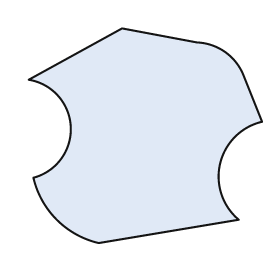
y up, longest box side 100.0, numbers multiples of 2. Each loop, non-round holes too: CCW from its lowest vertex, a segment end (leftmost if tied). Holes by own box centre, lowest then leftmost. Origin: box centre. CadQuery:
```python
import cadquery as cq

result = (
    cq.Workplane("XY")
    .moveTo(-20.0, -46.0)
    .lineTo(40.0, -36.0)
    .threePointArc((32.0, -12.0), (50.0, 6.0))
    .lineTo(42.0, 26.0)
    .threePointArc((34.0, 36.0), (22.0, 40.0))
    .lineTo(-10.0, 46.0)
    .lineTo(-50.0, 24.0)
    .threePointArc((-32.0, 4.0), (-48.0, -18.0))
    .threePointArc((-38.0, -36.0), (-20.0, -46.0))
    .close()
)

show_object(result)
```